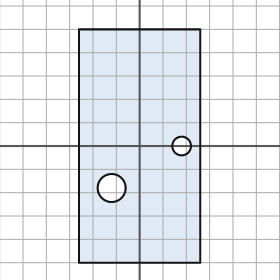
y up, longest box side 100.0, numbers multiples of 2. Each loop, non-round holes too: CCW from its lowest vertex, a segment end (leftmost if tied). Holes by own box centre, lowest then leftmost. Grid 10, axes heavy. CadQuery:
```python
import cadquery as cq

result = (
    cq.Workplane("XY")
    .moveTo(-26.0, -50.0)
    .lineTo(26.0, -50.0)
    .lineTo(26.0, 50.0)
    .lineTo(-26.0, 50.0)
    .close()
    .moveTo(-12.0, -18.0)
    .circle(6.0)
    .moveTo(18.0, 0.0)
    .circle(4.0)
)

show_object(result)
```